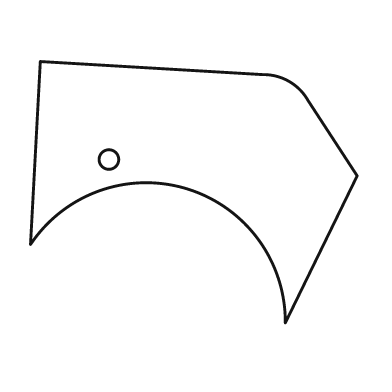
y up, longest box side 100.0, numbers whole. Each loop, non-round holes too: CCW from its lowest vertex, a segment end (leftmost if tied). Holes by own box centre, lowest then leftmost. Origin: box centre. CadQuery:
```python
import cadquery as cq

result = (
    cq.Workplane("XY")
    .moveTo(28.0, -40.0)
    .lineTo(50.0, 5.0)
    .lineTo(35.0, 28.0)
    .threePointArc((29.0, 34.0), (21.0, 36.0))
    .lineTo(-47.0, 40.0)
    .lineTo(-50.0, -16.0)
    .threePointArc((-2.0, 1.0), (28.0, -40.0))
    .close()
    .moveTo(-26.0, 10.0)
    .circle(3.0)
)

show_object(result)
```